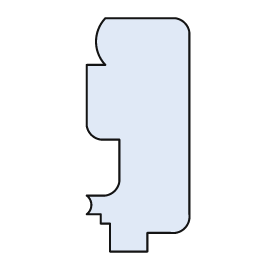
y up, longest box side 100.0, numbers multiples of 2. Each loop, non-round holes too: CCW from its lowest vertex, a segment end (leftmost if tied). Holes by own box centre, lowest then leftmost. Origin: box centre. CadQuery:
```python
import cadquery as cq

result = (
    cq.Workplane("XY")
    .moveTo(-12.0, -50.0)
    .lineTo(4.0, -50.0)
    .lineTo(4.0, -42.0)
    .lineTo(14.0, -42.0)
    .threePointArc((20.0, -40.0), (22.0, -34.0))
    .lineTo(22.0, 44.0)
    .threePointArc((20.0, 48.0), (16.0, 50.0))
    .lineTo(-14.0, 50.0)
    .threePointArc((-18.0, 40.0), (-14.0, 30.0))
    .lineTo(-22.0, 30.0)
    .lineTo(-22.0, 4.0)
    .threePointArc((-20.0, 0.0), (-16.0, -2.0))
    .lineTo(-8.0, -2.0)
    .lineTo(-8.0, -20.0)
    .threePointArc((-10.0, -24.0), (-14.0, -26.0))
    .lineTo(-22.0, -26.0)
    .threePointArc((-20.0, -30.0), (-22.0, -34.0))
    .lineTo(-16.0, -34.0)
    .lineTo(-16.0, -38.0)
    .lineTo(-12.0, -38.0)
    .close()
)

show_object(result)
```